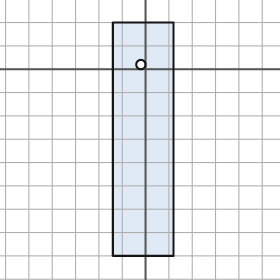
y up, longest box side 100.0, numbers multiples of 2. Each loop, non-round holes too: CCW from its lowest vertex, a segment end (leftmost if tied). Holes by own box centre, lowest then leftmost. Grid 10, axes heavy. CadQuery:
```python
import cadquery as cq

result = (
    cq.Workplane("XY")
    .moveTo(-14.0, -80.0)
    .lineTo(12.0, -80.0)
    .lineTo(12.0, 20.0)
    .lineTo(-14.0, 20.0)
    .close()
    .moveTo(-2.0, 2.0)
    .circle(2.0)
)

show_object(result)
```